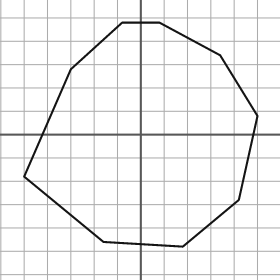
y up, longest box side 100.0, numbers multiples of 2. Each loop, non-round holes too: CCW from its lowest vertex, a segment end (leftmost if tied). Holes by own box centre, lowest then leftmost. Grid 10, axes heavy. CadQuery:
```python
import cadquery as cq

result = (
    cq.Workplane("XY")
    .moveTo(18.0, -48.0)
    .lineTo(42.0, -28.0)
    .lineTo(50.0, 8.0)
    .lineTo(34.0, 34.0)
    .lineTo(8.0, 48.0)
    .lineTo(-8.0, 48.0)
    .lineTo(-30.0, 28.0)
    .lineTo(-50.0, -18.0)
    .lineTo(-16.0, -46.0)
    .close()
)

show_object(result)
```